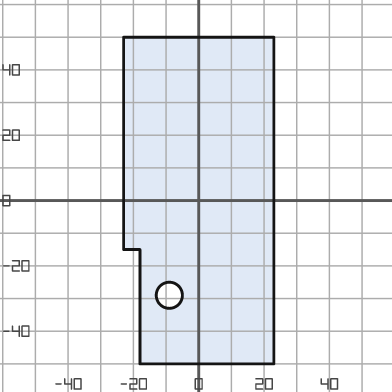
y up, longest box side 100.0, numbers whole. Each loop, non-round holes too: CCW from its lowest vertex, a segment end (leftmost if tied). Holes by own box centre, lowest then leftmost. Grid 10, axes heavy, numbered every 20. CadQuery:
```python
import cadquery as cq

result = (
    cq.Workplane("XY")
    .moveTo(-18.0, -50.0)
    .lineTo(23.0, -50.0)
    .lineTo(23.0, 50.0)
    .lineTo(-23.0, 50.0)
    .lineTo(-23.0, -15.0)
    .lineTo(-18.0, -15.0)
    .close()
    .moveTo(-9.0, -29.0)
    .circle(4.0)
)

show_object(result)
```